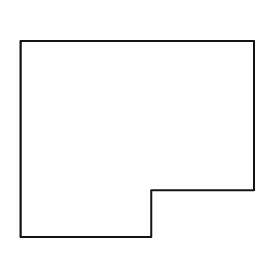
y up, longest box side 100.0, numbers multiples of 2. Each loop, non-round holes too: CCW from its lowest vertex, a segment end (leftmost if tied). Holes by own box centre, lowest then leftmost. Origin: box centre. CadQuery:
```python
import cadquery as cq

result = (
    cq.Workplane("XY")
    .moveTo(-50.0, -42.0)
    .lineTo(6.0, -42.0)
    .lineTo(6.0, -22.0)
    .lineTo(50.0, -22.0)
    .lineTo(50.0, 42.0)
    .lineTo(-50.0, 42.0)
    .close()
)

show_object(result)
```